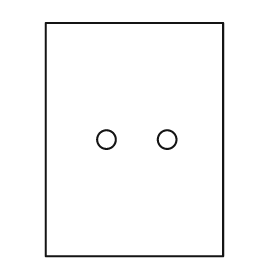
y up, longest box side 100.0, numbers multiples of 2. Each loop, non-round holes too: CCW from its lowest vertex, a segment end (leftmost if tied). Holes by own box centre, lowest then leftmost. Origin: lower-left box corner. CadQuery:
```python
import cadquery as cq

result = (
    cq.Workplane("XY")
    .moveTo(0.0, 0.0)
    .lineTo(76.0, 0.0)
    .lineTo(76.0, 100.0)
    .lineTo(0.0, 100.0)
    .close()
    .moveTo(26.0, 50.0)
    .circle(4.0)
    .moveTo(52.0, 50.0)
    .circle(4.0)
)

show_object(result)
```